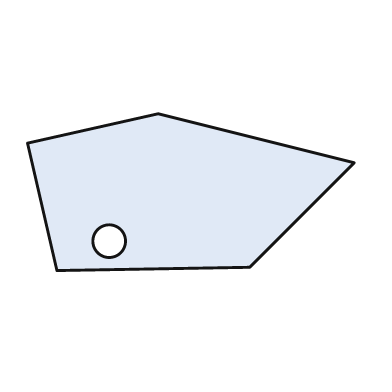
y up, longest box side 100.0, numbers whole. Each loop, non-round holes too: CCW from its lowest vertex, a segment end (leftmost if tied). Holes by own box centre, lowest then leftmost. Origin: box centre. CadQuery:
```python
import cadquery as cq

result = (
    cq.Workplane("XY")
    .moveTo(-41.0, -24.0)
    .lineTo(18.0, -23.0)
    .lineTo(50.0, 9.0)
    .lineTo(-10.0, 24.0)
    .lineTo(-50.0, 15.0)
    .close()
    .moveTo(-25.0, -15.0)
    .circle(5.0)
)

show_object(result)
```